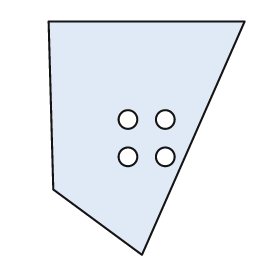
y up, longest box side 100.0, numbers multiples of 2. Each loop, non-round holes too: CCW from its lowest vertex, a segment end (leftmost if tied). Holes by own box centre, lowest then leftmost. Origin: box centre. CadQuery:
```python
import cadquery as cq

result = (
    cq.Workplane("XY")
    .moveTo(-2.0, -50.0)
    .lineTo(42.0, 50.0)
    .lineTo(-42.0, 50.0)
    .lineTo(-40.0, -22.0)
    .close()
    .moveTo(-8.0, -8.0)
    .circle(4.0)
    .moveTo(8.0, -8.0)
    .circle(4.0)
    .moveTo(-8.0, 8.0)
    .circle(4.0)
    .moveTo(8.0, 8.0)
    .circle(4.0)
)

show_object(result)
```